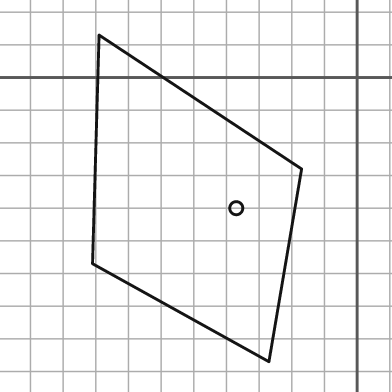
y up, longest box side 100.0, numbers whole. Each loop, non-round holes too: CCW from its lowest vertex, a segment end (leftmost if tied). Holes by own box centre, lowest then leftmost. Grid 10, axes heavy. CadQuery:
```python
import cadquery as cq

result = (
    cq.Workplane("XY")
    .moveTo(-27.0, -87.0)
    .lineTo(-17.0, -28.0)
    .lineTo(-79.0, 13.0)
    .lineTo(-81.0, -57.0)
    .close()
    .moveTo(-37.0, -40.0)
    .circle(2.0)
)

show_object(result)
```